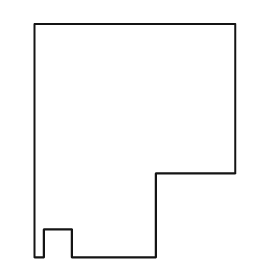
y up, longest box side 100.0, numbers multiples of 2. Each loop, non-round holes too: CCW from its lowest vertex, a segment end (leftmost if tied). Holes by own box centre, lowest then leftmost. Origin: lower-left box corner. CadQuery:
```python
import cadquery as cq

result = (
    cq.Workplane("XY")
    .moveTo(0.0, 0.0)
    .lineTo(4.0, 0.0)
    .lineTo(4.0, 12.0)
    .lineTo(16.0, 12.0)
    .lineTo(16.0, 0.0)
    .lineTo(52.0, 0.0)
    .lineTo(52.0, 36.0)
    .lineTo(86.0, 36.0)
    .lineTo(86.0, 100.0)
    .lineTo(0.0, 100.0)
    .close()
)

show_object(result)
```